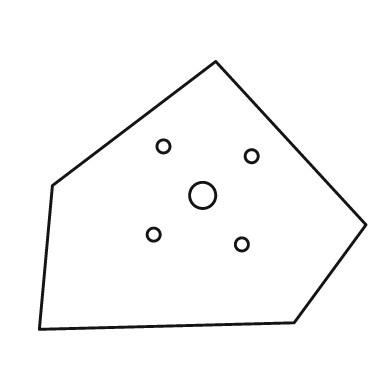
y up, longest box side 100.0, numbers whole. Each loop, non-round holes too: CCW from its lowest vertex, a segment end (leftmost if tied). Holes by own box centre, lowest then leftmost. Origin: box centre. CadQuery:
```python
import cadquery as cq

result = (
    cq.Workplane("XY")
    .moveTo(-50.0, -41.0)
    .lineTo(28.0, -39.0)
    .lineTo(50.0, -9.0)
    .lineTo(4.0, 41.0)
    .lineTo(-46.0, 3.0)
    .close()
    .moveTo(12.0, -15.0)
    .circle(2.0)
    .moveTo(-15.0, -12.0)
    .circle(2.0)
    .moveTo(0.0, 0.0)
    .circle(4.0)
    .moveTo(15.0, 12.0)
    .circle(2.0)
    .moveTo(-12.0, 15.0)
    .circle(2.0)
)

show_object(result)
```